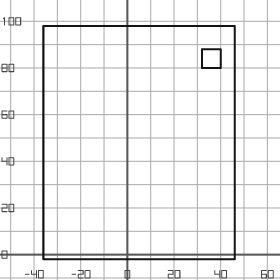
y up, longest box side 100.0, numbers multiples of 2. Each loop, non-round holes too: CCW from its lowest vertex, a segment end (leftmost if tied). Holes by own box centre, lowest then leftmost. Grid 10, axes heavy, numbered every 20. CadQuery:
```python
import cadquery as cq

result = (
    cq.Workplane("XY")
    .moveTo(-36.0, -2.0)
    .lineTo(46.0, -2.0)
    .lineTo(46.0, 98.0)
    .lineTo(-36.0, 98.0)
    .close()
    .moveTo(32.0, 80.0)
    .lineTo(40.0, 80.0)
    .lineTo(40.0, 88.0)
    .lineTo(32.0, 88.0)
    .close()
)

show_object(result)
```